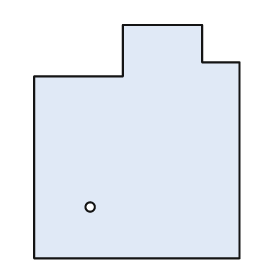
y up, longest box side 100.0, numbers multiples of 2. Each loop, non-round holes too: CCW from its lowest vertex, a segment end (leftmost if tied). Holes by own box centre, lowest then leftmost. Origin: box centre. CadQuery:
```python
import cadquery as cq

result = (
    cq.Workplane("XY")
    .moveTo(-44.0, -50.0)
    .lineTo(44.0, -50.0)
    .lineTo(44.0, 34.0)
    .lineTo(28.0, 34.0)
    .lineTo(28.0, 50.0)
    .lineTo(-6.0, 50.0)
    .lineTo(-6.0, 28.0)
    .lineTo(-44.0, 28.0)
    .close()
    .moveTo(-20.0, -28.0)
    .circle(2.0)
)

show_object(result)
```